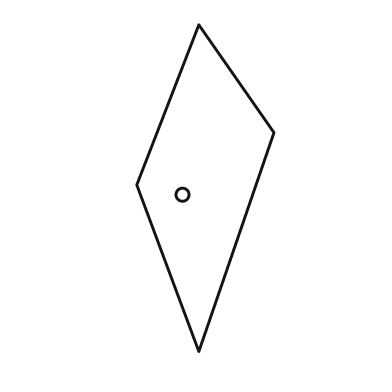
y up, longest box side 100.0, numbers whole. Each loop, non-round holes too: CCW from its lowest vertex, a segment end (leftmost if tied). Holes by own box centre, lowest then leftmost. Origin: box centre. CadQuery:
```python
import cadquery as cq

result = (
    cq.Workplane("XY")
    .moveTo(-2.0, -50.0)
    .lineTo(21.0, 17.0)
    .lineTo(-2.0, 50.0)
    .lineTo(-21.0, 1.0)
    .close()
    .moveTo(-7.0, -2.0)
    .circle(2.0)
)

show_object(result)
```